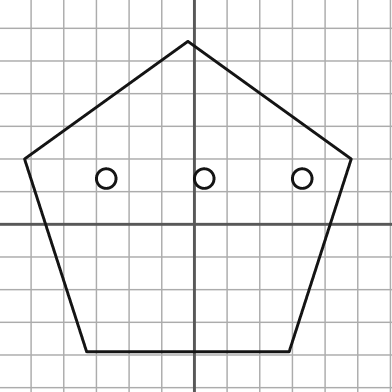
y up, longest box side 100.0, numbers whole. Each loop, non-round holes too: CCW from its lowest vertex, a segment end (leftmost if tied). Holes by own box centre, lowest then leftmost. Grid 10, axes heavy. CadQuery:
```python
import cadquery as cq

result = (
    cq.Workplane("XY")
    .moveTo(-33.0, -39.0)
    .lineTo(29.0, -39.0)
    .lineTo(48.0, 20.0)
    .lineTo(-2.0, 56.0)
    .lineTo(-52.0, 20.0)
    .close()
    .moveTo(-27.0, 14.0)
    .circle(3.0)
    .moveTo(3.0, 14.0)
    .circle(3.0)
    .moveTo(33.0, 14.0)
    .circle(3.0)
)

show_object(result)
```